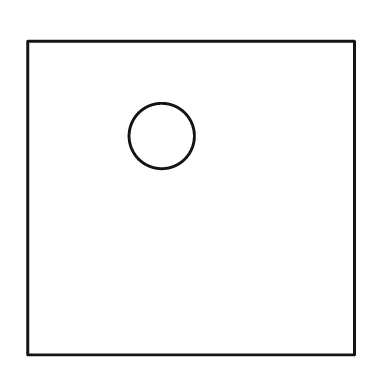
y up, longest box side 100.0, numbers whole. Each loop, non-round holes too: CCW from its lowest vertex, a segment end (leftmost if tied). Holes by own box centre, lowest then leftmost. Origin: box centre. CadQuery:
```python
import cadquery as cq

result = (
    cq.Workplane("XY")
    .moveTo(-50.0, -48.0)
    .lineTo(50.0, -48.0)
    .lineTo(50.0, 48.0)
    .lineTo(-50.0, 48.0)
    .close()
    .moveTo(-9.0, 19.0)
    .circle(10.0)
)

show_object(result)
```